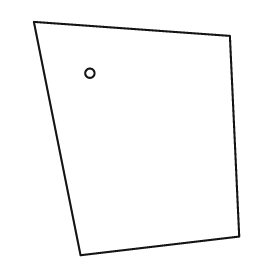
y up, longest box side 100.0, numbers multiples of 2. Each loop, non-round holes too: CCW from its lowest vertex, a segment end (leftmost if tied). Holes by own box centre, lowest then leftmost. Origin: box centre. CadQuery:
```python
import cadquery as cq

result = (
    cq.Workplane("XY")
    .moveTo(-24.0, -50.0)
    .lineTo(44.0, -42.0)
    .lineTo(40.0, 44.0)
    .lineTo(-44.0, 50.0)
    .close()
    .moveTo(-20.0, 28.0)
    .circle(2.0)
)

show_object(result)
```